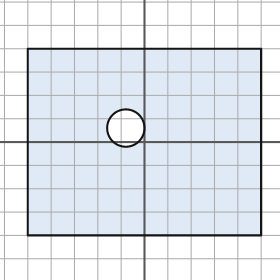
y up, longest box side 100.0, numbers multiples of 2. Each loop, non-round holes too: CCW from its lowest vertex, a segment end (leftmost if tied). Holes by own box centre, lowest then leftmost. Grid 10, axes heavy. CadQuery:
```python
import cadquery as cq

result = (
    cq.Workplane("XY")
    .moveTo(-50.0, -40.0)
    .lineTo(50.0, -40.0)
    .lineTo(50.0, 40.0)
    .lineTo(-50.0, 40.0)
    .close()
    .moveTo(-8.0, 6.0)
    .circle(8.0)
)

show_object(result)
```